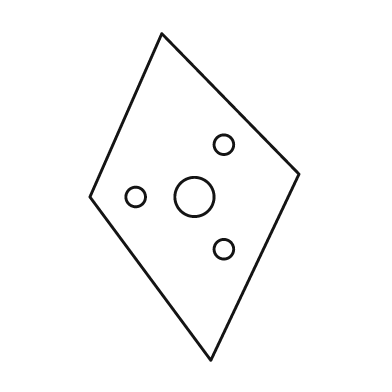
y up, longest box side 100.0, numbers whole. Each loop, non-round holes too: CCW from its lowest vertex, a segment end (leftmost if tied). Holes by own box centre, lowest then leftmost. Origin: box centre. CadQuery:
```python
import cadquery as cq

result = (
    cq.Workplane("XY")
    .moveTo(5.0, -50.0)
    .lineTo(32.0, 7.0)
    .lineTo(-10.0, 50.0)
    .lineTo(-32.0, 0.0)
    .close()
    .moveTo(9.0, -16.0)
    .circle(3.0)
    .moveTo(-18.0, 0.0)
    .circle(3.0)
    .moveTo(0.0, 0.0)
    .circle(6.0)
    .moveTo(9.0, 16.0)
    .circle(3.0)
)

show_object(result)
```